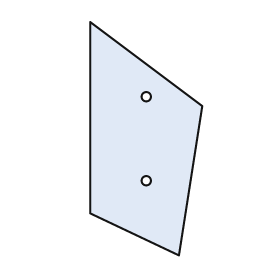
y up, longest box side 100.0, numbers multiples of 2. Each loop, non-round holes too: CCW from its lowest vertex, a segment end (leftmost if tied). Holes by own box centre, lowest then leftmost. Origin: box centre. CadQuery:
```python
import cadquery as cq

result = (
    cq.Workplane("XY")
    .moveTo(14.0, -50.0)
    .lineTo(24.0, 14.0)
    .lineTo(-24.0, 50.0)
    .lineTo(-24.0, -32.0)
    .close()
    .moveTo(0.0, -18.0)
    .circle(2.0)
    .moveTo(0.0, 18.0)
    .circle(2.0)
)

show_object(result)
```